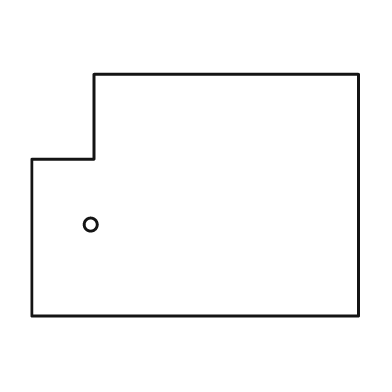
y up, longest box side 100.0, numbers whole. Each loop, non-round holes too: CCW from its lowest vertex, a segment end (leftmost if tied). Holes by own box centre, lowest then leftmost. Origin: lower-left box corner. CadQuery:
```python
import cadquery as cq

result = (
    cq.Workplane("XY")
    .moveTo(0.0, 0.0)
    .lineTo(100.0, 0.0)
    .lineTo(100.0, 74.0)
    .lineTo(19.0, 74.0)
    .lineTo(19.0, 48.0)
    .lineTo(0.0, 48.0)
    .close()
    .moveTo(18.0, 28.0)
    .circle(2.0)
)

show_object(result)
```